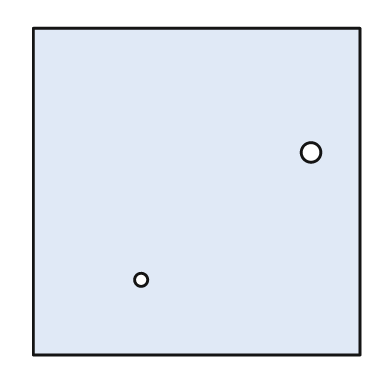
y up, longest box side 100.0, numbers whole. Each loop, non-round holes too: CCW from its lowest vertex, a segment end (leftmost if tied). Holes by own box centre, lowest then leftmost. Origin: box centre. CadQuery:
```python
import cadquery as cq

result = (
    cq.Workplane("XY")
    .moveTo(-50.0, -50.0)
    .lineTo(50.0, -50.0)
    .lineTo(50.0, 50.0)
    .lineTo(-50.0, 50.0)
    .close()
    .moveTo(-17.0, -27.0)
    .circle(2.0)
    .moveTo(35.0, 12.0)
    .circle(3.0)
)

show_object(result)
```